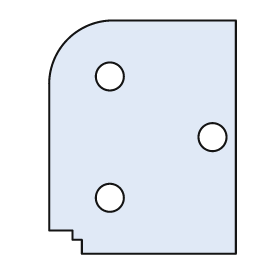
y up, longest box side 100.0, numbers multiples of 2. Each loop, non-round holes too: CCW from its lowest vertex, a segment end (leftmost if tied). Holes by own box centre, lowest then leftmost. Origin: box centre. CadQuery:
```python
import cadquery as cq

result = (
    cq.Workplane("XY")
    .moveTo(-26.0, -50.0)
    .lineTo(40.0, -50.0)
    .lineTo(40.0, 50.0)
    .lineTo(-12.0, 50.0)
    .threePointArc((-32.0, 42.0), (-40.0, 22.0))
    .lineTo(-40.0, -40.0)
    .lineTo(-30.0, -40.0)
    .lineTo(-30.0, -44.0)
    .lineTo(-26.0, -44.0)
    .close()
    .moveTo(-14.0, -26.0)
    .circle(6.0)
    .moveTo(30.0, 0.0)
    .circle(6.0)
    .moveTo(-14.0, 26.0)
    .circle(6.0)
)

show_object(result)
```